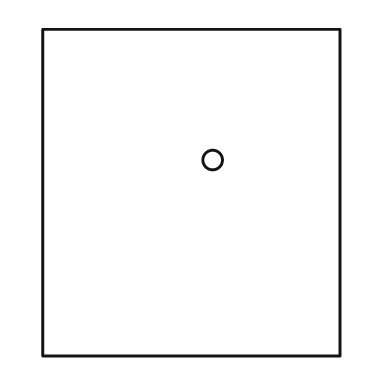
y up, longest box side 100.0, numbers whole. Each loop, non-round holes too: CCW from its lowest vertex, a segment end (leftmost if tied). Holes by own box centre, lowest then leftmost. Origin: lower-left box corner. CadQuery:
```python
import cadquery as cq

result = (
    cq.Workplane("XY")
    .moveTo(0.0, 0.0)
    .lineTo(91.0, 0.0)
    .lineTo(91.0, 100.0)
    .lineTo(0.0, 100.0)
    .close()
    .moveTo(52.0, 60.0)
    .circle(3.0)
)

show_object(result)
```